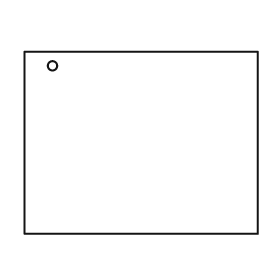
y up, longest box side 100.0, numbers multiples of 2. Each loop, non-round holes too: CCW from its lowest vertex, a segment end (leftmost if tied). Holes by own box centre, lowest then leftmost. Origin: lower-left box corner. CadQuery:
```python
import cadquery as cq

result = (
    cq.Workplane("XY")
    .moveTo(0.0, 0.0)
    .lineTo(100.0, 0.0)
    .lineTo(100.0, 78.0)
    .lineTo(0.0, 78.0)
    .close()
    .moveTo(12.0, 72.0)
    .circle(2.0)
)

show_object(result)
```